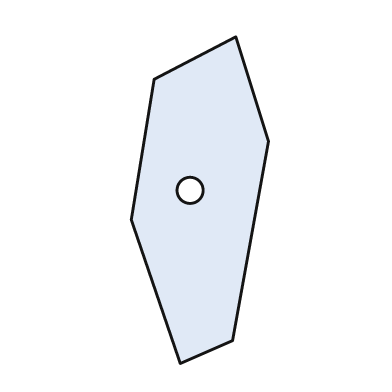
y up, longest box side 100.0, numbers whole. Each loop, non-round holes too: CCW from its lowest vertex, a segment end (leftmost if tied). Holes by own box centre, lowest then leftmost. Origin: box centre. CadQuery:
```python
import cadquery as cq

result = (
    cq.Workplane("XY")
    .moveTo(-6.0, -50.0)
    .lineTo(10.0, -43.0)
    .lineTo(21.0, 18.0)
    .lineTo(11.0, 50.0)
    .lineTo(-14.0, 37.0)
    .lineTo(-21.0, -6.0)
    .close()
    .moveTo(-3.0, 3.0)
    .circle(4.0)
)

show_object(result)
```